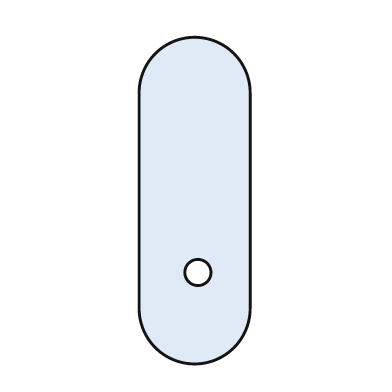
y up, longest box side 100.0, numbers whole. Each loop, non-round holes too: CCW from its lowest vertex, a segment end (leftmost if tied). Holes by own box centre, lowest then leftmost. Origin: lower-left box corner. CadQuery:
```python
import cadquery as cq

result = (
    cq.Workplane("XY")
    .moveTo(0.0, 17.0)
    .threePointArc((17.0, 0.0), (34.0, 17.0))
    .lineTo(34.0, 83.0)
    .threePointArc((17.0, 100.0), (0.0, 83.0))
    .close()
    .moveTo(18.0, 28.0)
    .circle(4.0)
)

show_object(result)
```